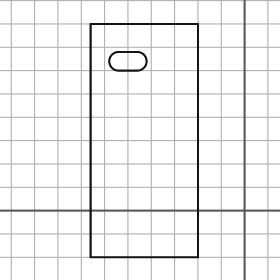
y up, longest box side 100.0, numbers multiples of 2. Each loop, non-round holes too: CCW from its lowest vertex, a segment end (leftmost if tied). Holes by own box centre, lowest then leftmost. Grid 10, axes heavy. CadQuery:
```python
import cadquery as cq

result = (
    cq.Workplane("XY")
    .moveTo(-66.0, -20.0)
    .lineTo(-20.0, -20.0)
    .lineTo(-20.0, 80.0)
    .lineTo(-66.0, 80.0)
    .close()
    .moveTo(-54.0, 60.0)
    .lineTo(-46.0, 60.0)
    .threePointArc((-42.0, 64.0), (-46.0, 68.0))
    .lineTo(-54.0, 68.0)
    .threePointArc((-58.0, 64.0), (-54.0, 60.0))
    .close()
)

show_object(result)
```